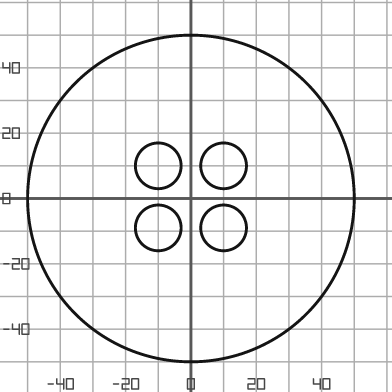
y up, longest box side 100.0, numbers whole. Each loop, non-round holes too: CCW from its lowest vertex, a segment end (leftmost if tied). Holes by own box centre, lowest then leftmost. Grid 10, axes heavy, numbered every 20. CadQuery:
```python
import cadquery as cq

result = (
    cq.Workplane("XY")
    .moveTo(0.0, 0.0)
    .circle(50.0)
    .moveTo(-10.0, -9.0)
    .circle(7.0)
    .moveTo(10.0, -9.0)
    .circle(7.0)
    .moveTo(-10.0, 10.0)
    .circle(7.0)
    .moveTo(10.0, 10.0)
    .circle(7.0)
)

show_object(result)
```